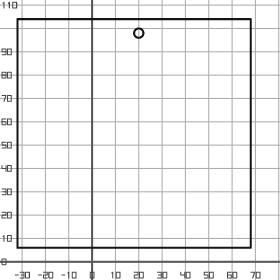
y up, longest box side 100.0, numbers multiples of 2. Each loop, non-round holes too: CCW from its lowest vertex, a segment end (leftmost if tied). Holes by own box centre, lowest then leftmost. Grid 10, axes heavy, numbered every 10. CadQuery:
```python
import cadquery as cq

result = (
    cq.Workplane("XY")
    .moveTo(-32.0, 6.0)
    .lineTo(68.0, 6.0)
    .lineTo(68.0, 104.0)
    .lineTo(-32.0, 104.0)
    .close()
    .moveTo(20.0, 98.0)
    .circle(2.0)
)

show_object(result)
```